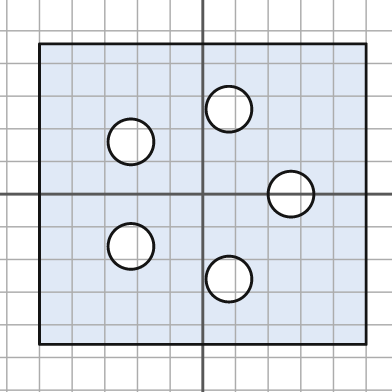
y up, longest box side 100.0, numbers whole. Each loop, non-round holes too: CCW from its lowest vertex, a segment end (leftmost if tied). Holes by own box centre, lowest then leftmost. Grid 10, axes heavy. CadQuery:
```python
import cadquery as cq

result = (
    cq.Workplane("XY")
    .moveTo(-50.0, -46.0)
    .lineTo(50.0, -46.0)
    .lineTo(50.0, 46.0)
    .lineTo(-50.0, 46.0)
    .close()
    .moveTo(8.0, -26.0)
    .circle(7.0)
    .moveTo(-22.0, -16.0)
    .circle(7.0)
    .moveTo(27.0, 0.0)
    .circle(7.0)
    .moveTo(-22.0, 16.0)
    .circle(7.0)
    .moveTo(8.0, 26.0)
    .circle(7.0)
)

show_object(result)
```